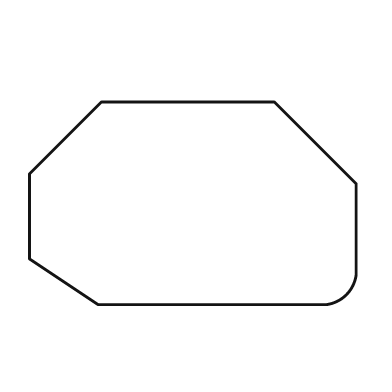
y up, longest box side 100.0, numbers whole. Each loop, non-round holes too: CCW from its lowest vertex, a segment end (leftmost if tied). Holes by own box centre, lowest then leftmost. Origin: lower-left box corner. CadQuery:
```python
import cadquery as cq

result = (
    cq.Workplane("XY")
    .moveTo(21.0, 0.0)
    .lineTo(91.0, 0.0)
    .threePointArc((97.0, 3.0), (100.0, 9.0))
    .lineTo(100.0, 37.0)
    .lineTo(75.0, 62.0)
    .lineTo(22.0, 62.0)
    .lineTo(0.0, 40.0)
    .lineTo(0.0, 14.0)
    .close()
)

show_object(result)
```